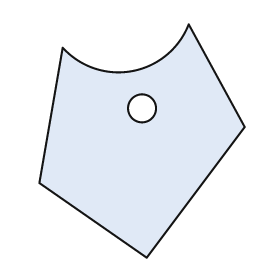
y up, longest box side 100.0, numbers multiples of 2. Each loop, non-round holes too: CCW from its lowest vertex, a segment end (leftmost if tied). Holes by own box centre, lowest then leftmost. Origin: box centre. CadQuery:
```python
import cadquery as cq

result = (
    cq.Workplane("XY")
    .moveTo(2.0, -50.0)
    .lineTo(44.0, 6.0)
    .lineTo(20.0, 50.0)
    .threePointArc((-4.0, 30.0), (-34.0, 40.0))
    .lineTo(-44.0, -18.0)
    .close()
    .moveTo(0.0, 14.0)
    .circle(6.0)
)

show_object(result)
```